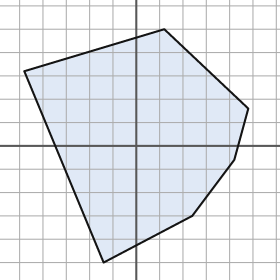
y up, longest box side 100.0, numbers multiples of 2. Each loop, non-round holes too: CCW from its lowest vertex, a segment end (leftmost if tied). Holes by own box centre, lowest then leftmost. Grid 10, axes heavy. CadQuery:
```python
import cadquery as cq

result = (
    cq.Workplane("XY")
    .moveTo(-14.0, -50.0)
    .lineTo(24.0, -30.0)
    .lineTo(42.0, -6.0)
    .lineTo(48.0, 16.0)
    .lineTo(12.0, 50.0)
    .lineTo(-48.0, 32.0)
    .close()
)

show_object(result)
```